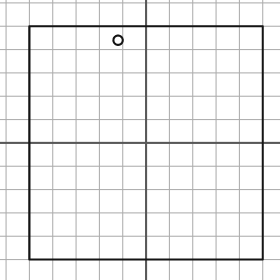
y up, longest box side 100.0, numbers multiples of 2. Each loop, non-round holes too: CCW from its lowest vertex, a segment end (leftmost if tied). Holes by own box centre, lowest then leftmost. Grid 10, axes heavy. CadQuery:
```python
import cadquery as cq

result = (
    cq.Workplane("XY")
    .moveTo(-50.0, -50.0)
    .lineTo(50.0, -50.0)
    .lineTo(50.0, 50.0)
    .lineTo(-50.0, 50.0)
    .close()
    .moveTo(-12.0, 44.0)
    .circle(2.0)
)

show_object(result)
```